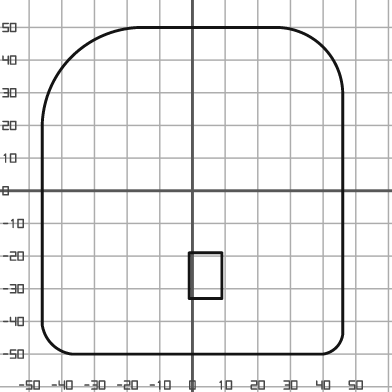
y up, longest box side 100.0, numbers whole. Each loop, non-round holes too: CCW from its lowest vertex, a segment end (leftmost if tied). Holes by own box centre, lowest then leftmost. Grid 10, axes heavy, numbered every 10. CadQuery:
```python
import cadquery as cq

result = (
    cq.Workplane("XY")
    .moveTo(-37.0, -50.0)
    .lineTo(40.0, -50.0)
    .threePointArc((44.0, -48.0), (46.0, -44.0))
    .lineTo(46.0, 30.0)
    .threePointArc((40.0, 44.0), (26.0, 50.0))
    .lineTo(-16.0, 50.0)
    .threePointArc((-37.0, 41.0), (-46.0, 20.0))
    .lineTo(-46.0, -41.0)
    .threePointArc((-43.0, -47.0), (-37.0, -50.0))
    .close()
    .moveTo(-1.0, -33.0)
    .lineTo(9.0, -33.0)
    .lineTo(9.0, -19.0)
    .lineTo(-1.0, -19.0)
    .close()
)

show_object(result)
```